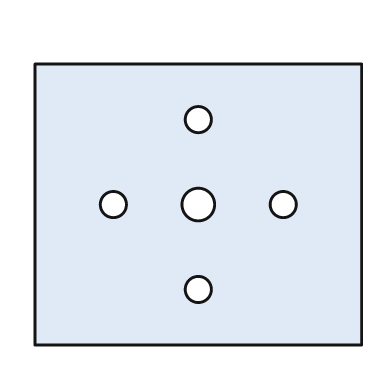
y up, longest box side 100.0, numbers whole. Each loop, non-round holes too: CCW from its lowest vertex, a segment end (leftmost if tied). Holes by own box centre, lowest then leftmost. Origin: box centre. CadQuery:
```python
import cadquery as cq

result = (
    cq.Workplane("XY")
    .moveTo(-50.0, -43.0)
    .lineTo(50.0, -43.0)
    .lineTo(50.0, 43.0)
    .lineTo(-50.0, 43.0)
    .close()
    .moveTo(0.0, -26.0)
    .circle(4.0)
    .moveTo(-26.0, 0.0)
    .circle(4.0)
    .moveTo(0.0, 0.0)
    .circle(5.0)
    .moveTo(26.0, 0.0)
    .circle(4.0)
    .moveTo(0.0, 26.0)
    .circle(4.0)
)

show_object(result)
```